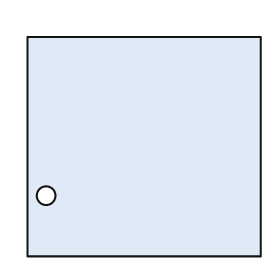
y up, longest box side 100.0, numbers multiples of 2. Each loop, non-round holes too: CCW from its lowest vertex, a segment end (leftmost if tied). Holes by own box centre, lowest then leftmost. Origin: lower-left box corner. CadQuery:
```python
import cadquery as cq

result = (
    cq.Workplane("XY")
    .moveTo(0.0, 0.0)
    .lineTo(100.0, 0.0)
    .lineTo(100.0, 94.0)
    .lineTo(0.0, 94.0)
    .close()
    .moveTo(8.0, 26.0)
    .circle(4.0)
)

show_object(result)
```